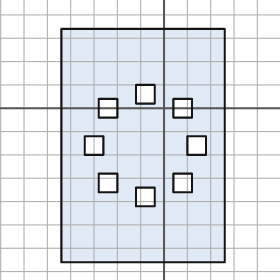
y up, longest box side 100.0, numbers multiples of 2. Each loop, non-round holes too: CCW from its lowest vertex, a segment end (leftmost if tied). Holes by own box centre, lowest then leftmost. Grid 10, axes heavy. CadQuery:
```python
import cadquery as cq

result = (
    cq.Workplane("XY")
    .moveTo(-44.0, -66.0)
    .lineTo(26.0, -66.0)
    .lineTo(26.0, 34.0)
    .lineTo(-44.0, 34.0)
    .close()
    .moveTo(-12.0, -42.0)
    .lineTo(-4.0, -42.0)
    .lineTo(-4.0, -34.0)
    .lineTo(-12.0, -34.0)
    .close()
    .moveTo(-28.0, -36.0)
    .lineTo(-20.0, -36.0)
    .lineTo(-20.0, -28.0)
    .lineTo(-28.0, -28.0)
    .close()
    .moveTo(4.0, -36.0)
    .lineTo(12.0, -36.0)
    .lineTo(12.0, -28.0)
    .lineTo(4.0, -28.0)
    .close()
    .moveTo(-34.0, -20.0)
    .lineTo(-26.0, -20.0)
    .lineTo(-26.0, -12.0)
    .lineTo(-34.0, -12.0)
    .close()
    .moveTo(10.0, -20.0)
    .lineTo(18.0, -20.0)
    .lineTo(18.0, -12.0)
    .lineTo(10.0, -12.0)
    .close()
    .moveTo(-28.0, -4.0)
    .lineTo(-20.0, -4.0)
    .lineTo(-20.0, 4.0)
    .lineTo(-28.0, 4.0)
    .close()
    .moveTo(4.0, -4.0)
    .lineTo(12.0, -4.0)
    .lineTo(12.0, 4.0)
    .lineTo(4.0, 4.0)
    .close()
    .moveTo(-12.0, 2.0)
    .lineTo(-4.0, 2.0)
    .lineTo(-4.0, 10.0)
    .lineTo(-12.0, 10.0)
    .close()
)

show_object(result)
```